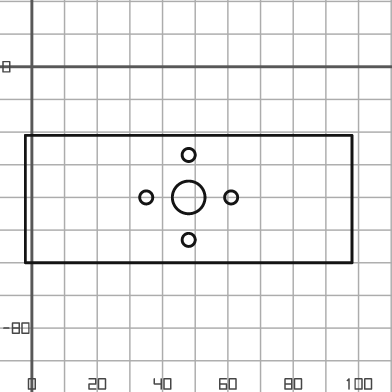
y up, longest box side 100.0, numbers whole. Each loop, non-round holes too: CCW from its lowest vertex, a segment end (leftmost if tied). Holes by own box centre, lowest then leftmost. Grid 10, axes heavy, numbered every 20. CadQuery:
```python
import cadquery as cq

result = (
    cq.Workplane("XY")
    .moveTo(-2.0, -60.0)
    .lineTo(98.0, -60.0)
    .lineTo(98.0, -21.0)
    .lineTo(-2.0, -21.0)
    .close()
    .moveTo(48.0, -53.0)
    .circle(2.0)
    .moveTo(35.0, -40.0)
    .circle(2.0)
    .moveTo(48.0, -40.0)
    .circle(5.0)
    .moveTo(61.0, -40.0)
    .circle(2.0)
    .moveTo(48.0, -27.0)
    .circle(2.0)
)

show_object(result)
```